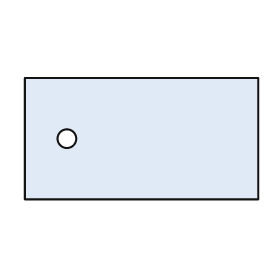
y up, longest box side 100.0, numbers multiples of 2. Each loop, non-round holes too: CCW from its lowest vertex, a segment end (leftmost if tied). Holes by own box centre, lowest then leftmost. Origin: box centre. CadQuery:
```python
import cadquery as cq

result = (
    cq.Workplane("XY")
    .moveTo(-50.0, -26.0)
    .lineTo(50.0, -26.0)
    .lineTo(50.0, 26.0)
    .lineTo(-50.0, 26.0)
    .close()
    .moveTo(-32.0, 0.0)
    .circle(4.0)
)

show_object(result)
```